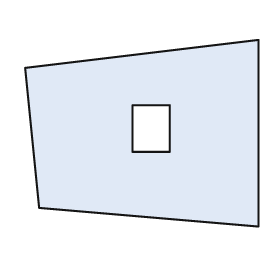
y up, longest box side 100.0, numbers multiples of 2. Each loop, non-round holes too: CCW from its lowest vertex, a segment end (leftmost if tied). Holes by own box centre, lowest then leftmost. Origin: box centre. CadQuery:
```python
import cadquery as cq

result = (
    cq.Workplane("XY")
    .moveTo(50.0, -40.0)
    .lineTo(50.0, 40.0)
    .lineTo(-50.0, 28.0)
    .lineTo(-44.0, -32.0)
    .close()
    .moveTo(-4.0, -8.0)
    .lineTo(12.0, -8.0)
    .lineTo(12.0, 12.0)
    .lineTo(-4.0, 12.0)
    .close()
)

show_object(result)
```